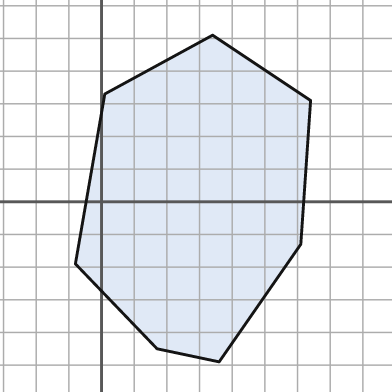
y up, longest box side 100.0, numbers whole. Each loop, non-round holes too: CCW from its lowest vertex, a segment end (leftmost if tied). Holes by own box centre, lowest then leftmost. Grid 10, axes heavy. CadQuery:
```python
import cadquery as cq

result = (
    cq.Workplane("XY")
    .moveTo(36.0, -49.0)
    .lineTo(61.0, -13.0)
    .lineTo(64.0, 31.0)
    .lineTo(34.0, 51.0)
    .lineTo(1.0, 33.0)
    .lineTo(-8.0, -19.0)
    .lineTo(17.0, -45.0)
    .close()
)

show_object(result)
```